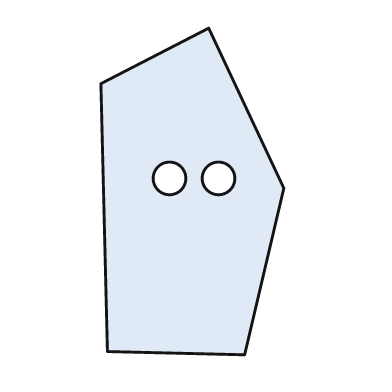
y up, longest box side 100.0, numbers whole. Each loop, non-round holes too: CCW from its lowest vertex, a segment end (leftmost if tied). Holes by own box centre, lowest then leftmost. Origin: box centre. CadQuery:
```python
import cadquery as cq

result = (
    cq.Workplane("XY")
    .moveTo(16.0, -50.0)
    .lineTo(28.0, 1.0)
    .lineTo(5.0, 50.0)
    .lineTo(-28.0, 33.0)
    .lineTo(-26.0, -49.0)
    .close()
    .moveTo(-7.0, 4.0)
    .circle(5.0)
    .moveTo(8.0, 4.0)
    .circle(5.0)
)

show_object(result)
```